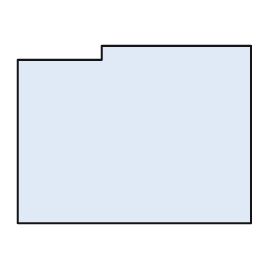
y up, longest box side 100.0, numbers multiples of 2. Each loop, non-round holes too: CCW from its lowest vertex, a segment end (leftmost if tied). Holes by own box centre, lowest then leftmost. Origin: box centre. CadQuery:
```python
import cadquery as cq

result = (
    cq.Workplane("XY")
    .moveTo(-50.0, -38.0)
    .lineTo(50.0, -38.0)
    .lineTo(50.0, 38.0)
    .lineTo(-14.0, 38.0)
    .lineTo(-14.0, 32.0)
    .lineTo(-50.0, 32.0)
    .close()
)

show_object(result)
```